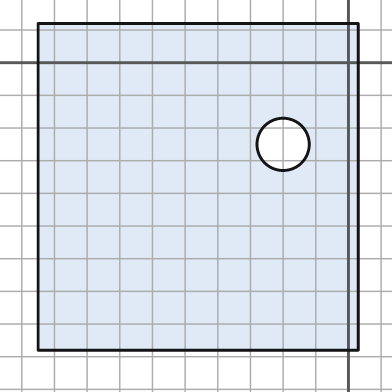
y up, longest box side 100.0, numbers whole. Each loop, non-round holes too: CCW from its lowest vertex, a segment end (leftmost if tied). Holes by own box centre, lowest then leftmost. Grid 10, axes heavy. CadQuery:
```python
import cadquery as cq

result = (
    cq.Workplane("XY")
    .moveTo(-95.0, -88.0)
    .lineTo(3.0, -88.0)
    .lineTo(3.0, 12.0)
    .lineTo(-95.0, 12.0)
    .close()
    .moveTo(-20.0, -25.0)
    .circle(8.0)
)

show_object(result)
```